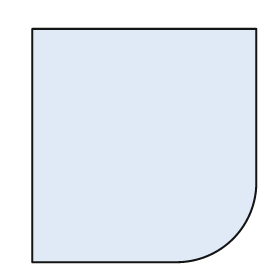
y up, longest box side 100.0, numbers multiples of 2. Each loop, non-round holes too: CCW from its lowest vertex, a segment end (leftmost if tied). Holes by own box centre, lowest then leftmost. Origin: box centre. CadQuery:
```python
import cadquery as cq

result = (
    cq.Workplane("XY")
    .moveTo(-48.0, -50.0)
    .lineTo(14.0, -50.0)
    .threePointArc((38.0, -40.0), (48.0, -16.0))
    .lineTo(48.0, 50.0)
    .lineTo(-48.0, 50.0)
    .close()
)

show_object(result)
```